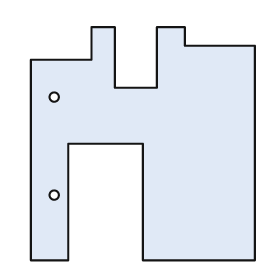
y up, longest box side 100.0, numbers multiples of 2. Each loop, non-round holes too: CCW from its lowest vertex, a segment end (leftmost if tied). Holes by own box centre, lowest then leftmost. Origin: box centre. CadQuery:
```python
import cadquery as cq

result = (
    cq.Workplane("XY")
    .moveTo(-48.0, -50.0)
    .lineTo(-32.0, -50.0)
    .lineTo(-32.0, 0.0)
    .lineTo(0.0, 0.0)
    .lineTo(0.0, -50.0)
    .lineTo(48.0, -50.0)
    .lineTo(48.0, 42.0)
    .lineTo(18.0, 42.0)
    .lineTo(18.0, 50.0)
    .lineTo(6.0, 50.0)
    .lineTo(6.0, 24.0)
    .lineTo(-12.0, 24.0)
    .lineTo(-12.0, 50.0)
    .lineTo(-22.0, 50.0)
    .lineTo(-22.0, 36.0)
    .lineTo(-48.0, 36.0)
    .close()
    .moveTo(-38.0, -22.0)
    .circle(2.0)
    .moveTo(-38.0, 20.0)
    .circle(2.0)
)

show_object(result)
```